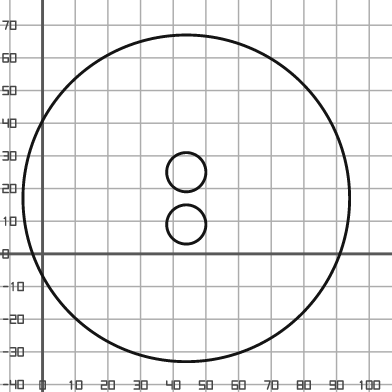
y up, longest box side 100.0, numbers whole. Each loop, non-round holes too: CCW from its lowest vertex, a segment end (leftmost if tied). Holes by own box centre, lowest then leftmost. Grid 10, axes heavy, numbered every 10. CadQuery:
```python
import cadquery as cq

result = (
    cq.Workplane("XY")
    .moveTo(44.0, 17.0)
    .circle(50.0)
    .moveTo(44.0, 9.0)
    .circle(6.0)
    .moveTo(44.0, 25.0)
    .circle(6.0)
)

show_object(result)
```